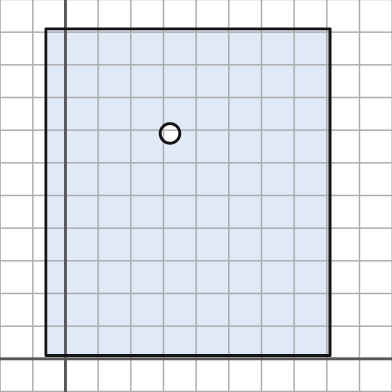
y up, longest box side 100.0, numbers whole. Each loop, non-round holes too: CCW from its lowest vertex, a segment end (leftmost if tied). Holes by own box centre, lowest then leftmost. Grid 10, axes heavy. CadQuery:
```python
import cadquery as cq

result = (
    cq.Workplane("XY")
    .moveTo(-6.0, 1.0)
    .lineTo(81.0, 1.0)
    .lineTo(81.0, 101.0)
    .lineTo(-6.0, 101.0)
    .close()
    .moveTo(32.0, 69.0)
    .circle(3.0)
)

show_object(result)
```